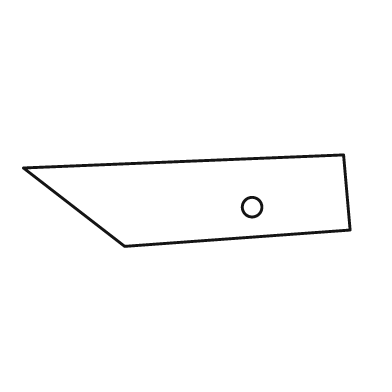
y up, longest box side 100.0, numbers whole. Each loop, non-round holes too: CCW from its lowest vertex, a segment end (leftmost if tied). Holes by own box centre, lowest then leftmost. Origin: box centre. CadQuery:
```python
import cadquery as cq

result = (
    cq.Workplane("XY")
    .moveTo(-19.0, -14.0)
    .lineTo(50.0, -9.0)
    .lineTo(48.0, 14.0)
    .lineTo(-50.0, 10.0)
    .close()
    .moveTo(20.0, -2.0)
    .circle(3.0)
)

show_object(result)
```